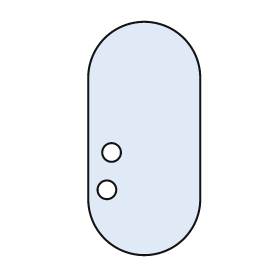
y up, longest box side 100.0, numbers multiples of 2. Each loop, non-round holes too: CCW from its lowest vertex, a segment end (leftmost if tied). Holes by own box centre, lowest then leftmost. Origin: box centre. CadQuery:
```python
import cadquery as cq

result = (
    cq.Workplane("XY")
    .moveTo(-24.0, -26.0)
    .threePointArc((0.0, -50.0), (24.0, -26.0))
    .lineTo(24.0, 26.0)
    .threePointArc((0.0, 50.0), (-24.0, 26.0))
    .close()
    .moveTo(-16.0, -22.0)
    .circle(4.0)
    .moveTo(-14.0, -6.0)
    .circle(4.0)
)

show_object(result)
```